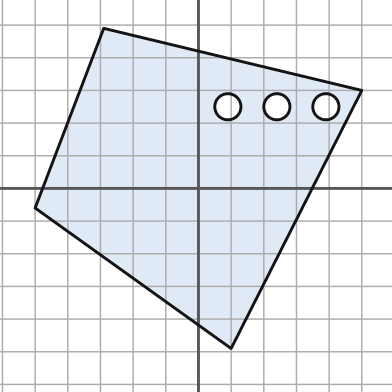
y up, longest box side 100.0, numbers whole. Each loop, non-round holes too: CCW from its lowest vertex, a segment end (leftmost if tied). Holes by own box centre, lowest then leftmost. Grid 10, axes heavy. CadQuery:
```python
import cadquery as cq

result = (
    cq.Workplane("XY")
    .moveTo(10.0, -49.0)
    .lineTo(50.0, 30.0)
    .lineTo(-29.0, 49.0)
    .lineTo(-50.0, -6.0)
    .close()
    .moveTo(9.0, 25.0)
    .circle(4.0)
    .moveTo(24.0, 25.0)
    .circle(4.0)
    .moveTo(39.0, 25.0)
    .circle(4.0)
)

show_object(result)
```